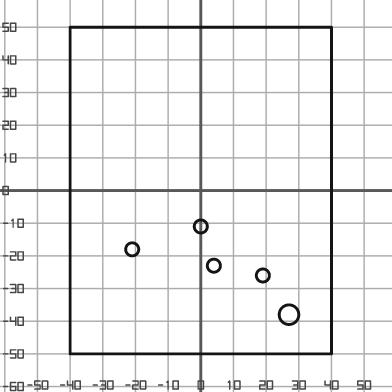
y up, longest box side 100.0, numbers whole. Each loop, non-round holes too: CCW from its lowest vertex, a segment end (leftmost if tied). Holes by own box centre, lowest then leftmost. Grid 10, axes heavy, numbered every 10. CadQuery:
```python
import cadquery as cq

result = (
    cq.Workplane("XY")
    .moveTo(-40.0, -50.0)
    .lineTo(40.0, -50.0)
    .lineTo(40.0, 50.0)
    .lineTo(-40.0, 50.0)
    .close()
    .moveTo(27.0, -38.0)
    .circle(3.0)
    .moveTo(19.0, -26.0)
    .circle(2.0)
    .moveTo(4.0, -23.0)
    .circle(2.0)
    .moveTo(-21.0, -18.0)
    .circle(2.0)
    .moveTo(0.0, -11.0)
    .circle(2.0)
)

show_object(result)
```